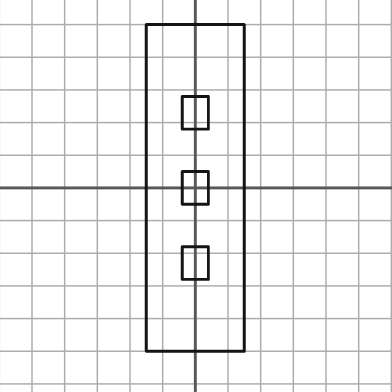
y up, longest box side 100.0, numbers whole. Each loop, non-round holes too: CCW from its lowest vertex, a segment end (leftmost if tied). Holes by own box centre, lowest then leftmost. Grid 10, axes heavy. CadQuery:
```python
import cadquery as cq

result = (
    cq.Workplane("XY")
    .moveTo(-15.0, -50.0)
    .lineTo(15.0, -50.0)
    .lineTo(15.0, 50.0)
    .lineTo(-15.0, 50.0)
    .close()
    .moveTo(-4.0, -28.0)
    .lineTo(4.0, -28.0)
    .lineTo(4.0, -18.0)
    .lineTo(-4.0, -18.0)
    .close()
    .moveTo(-4.0, -5.0)
    .lineTo(4.0, -5.0)
    .lineTo(4.0, 5.0)
    .lineTo(-4.0, 5.0)
    .close()
    .moveTo(-4.0, 18.0)
    .lineTo(4.0, 18.0)
    .lineTo(4.0, 28.0)
    .lineTo(-4.0, 28.0)
    .close()
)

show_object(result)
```